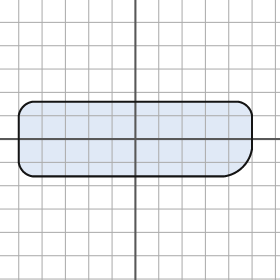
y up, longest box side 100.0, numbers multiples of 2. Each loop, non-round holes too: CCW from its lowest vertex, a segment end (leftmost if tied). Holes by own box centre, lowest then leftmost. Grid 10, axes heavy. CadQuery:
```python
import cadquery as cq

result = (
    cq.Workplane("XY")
    .moveTo(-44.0, -16.0)
    .lineTo(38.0, -16.0)
    .threePointArc((46.0, -12.0), (50.0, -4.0))
    .lineTo(50.0, 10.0)
    .threePointArc((48.0, 14.0), (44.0, 16.0))
    .lineTo(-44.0, 16.0)
    .threePointArc((-48.0, 14.0), (-50.0, 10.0))
    .lineTo(-50.0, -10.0)
    .threePointArc((-48.0, -14.0), (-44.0, -16.0))
    .close()
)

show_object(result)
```